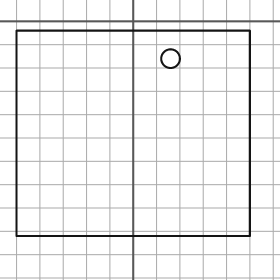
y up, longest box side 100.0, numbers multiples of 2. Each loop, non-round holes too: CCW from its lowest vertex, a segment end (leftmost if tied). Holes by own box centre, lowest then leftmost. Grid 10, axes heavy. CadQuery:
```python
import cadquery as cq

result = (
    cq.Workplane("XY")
    .moveTo(-50.0, -92.0)
    .lineTo(50.0, -92.0)
    .lineTo(50.0, -4.0)
    .lineTo(-50.0, -4.0)
    .close()
    .moveTo(16.0, -16.0)
    .circle(4.0)
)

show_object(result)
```